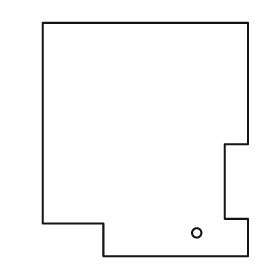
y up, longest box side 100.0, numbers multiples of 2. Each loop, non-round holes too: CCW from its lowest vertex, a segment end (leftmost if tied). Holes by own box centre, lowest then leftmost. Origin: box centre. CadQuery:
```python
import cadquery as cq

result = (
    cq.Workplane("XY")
    .moveTo(-18.0, -50.0)
    .lineTo(44.0, -50.0)
    .lineTo(44.0, -34.0)
    .lineTo(34.0, -34.0)
    .lineTo(34.0, -2.0)
    .lineTo(44.0, -2.0)
    .lineTo(44.0, 50.0)
    .lineTo(-44.0, 50.0)
    .lineTo(-44.0, -36.0)
    .lineTo(-18.0, -36.0)
    .close()
    .moveTo(22.0, -40.0)
    .circle(2.0)
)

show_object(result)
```